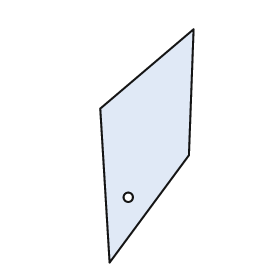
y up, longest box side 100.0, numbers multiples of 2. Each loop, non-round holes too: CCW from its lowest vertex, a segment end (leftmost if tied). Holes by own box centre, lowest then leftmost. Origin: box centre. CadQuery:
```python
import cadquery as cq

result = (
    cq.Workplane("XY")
    .moveTo(-16.0, -50.0)
    .lineTo(18.0, -4.0)
    .lineTo(20.0, 50.0)
    .lineTo(-20.0, 16.0)
    .close()
    .moveTo(-8.0, -22.0)
    .circle(2.0)
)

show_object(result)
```